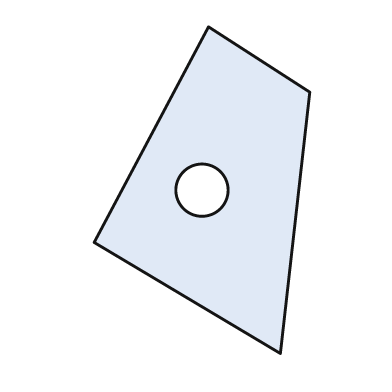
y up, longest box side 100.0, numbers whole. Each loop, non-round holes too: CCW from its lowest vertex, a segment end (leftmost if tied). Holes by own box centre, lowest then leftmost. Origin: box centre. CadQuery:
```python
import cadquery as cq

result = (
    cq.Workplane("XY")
    .moveTo(24.0, -50.0)
    .lineTo(33.0, 30.0)
    .lineTo(2.0, 50.0)
    .lineTo(-33.0, -16.0)
    .close()
    .moveTo(0.0, 0.0)
    .circle(8.0)
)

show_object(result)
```